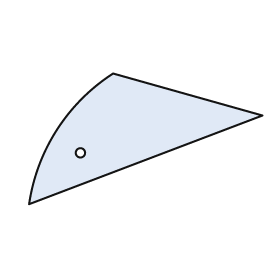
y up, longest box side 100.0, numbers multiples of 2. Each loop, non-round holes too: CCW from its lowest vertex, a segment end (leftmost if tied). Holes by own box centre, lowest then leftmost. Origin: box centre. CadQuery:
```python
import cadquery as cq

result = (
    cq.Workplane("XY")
    .moveTo(-50.0, -28.0)
    .lineTo(50.0, 10.0)
    .lineTo(-14.0, 28.0)
    .threePointArc((-38.0, 4.0), (-50.0, -28.0))
    .close()
    .moveTo(-28.0, -6.0)
    .circle(2.0)
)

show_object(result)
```